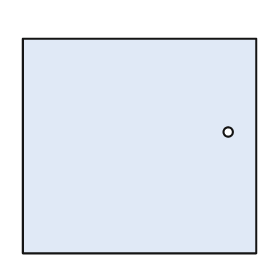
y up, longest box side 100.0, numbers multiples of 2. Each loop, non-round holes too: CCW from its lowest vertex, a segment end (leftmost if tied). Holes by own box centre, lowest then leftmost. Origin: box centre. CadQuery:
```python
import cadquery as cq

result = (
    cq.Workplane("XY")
    .moveTo(-50.0, -46.0)
    .lineTo(50.0, -46.0)
    .lineTo(50.0, 46.0)
    .lineTo(-50.0, 46.0)
    .close()
    .moveTo(38.0, 6.0)
    .circle(2.0)
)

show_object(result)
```